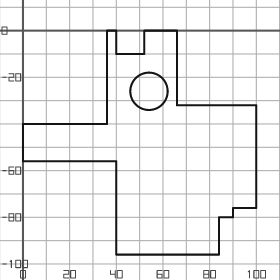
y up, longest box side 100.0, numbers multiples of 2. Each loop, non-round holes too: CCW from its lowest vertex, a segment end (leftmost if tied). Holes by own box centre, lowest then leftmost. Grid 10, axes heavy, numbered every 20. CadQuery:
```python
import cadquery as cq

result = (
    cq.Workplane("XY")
    .moveTo(40.0, -96.0)
    .lineTo(84.0, -96.0)
    .lineTo(84.0, -80.0)
    .lineTo(90.0, -80.0)
    .lineTo(90.0, -76.0)
    .lineTo(100.0, -76.0)
    .lineTo(100.0, -32.0)
    .lineTo(66.0, -32.0)
    .lineTo(66.0, 0.0)
    .lineTo(52.0, 0.0)
    .lineTo(52.0, -10.0)
    .lineTo(40.0, -10.0)
    .lineTo(40.0, 0.0)
    .lineTo(36.0, 0.0)
    .lineTo(36.0, -40.0)
    .lineTo(0.0, -40.0)
    .lineTo(0.0, -56.0)
    .lineTo(40.0, -56.0)
    .close()
    .moveTo(54.0, -26.0)
    .circle(8.0)
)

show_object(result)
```